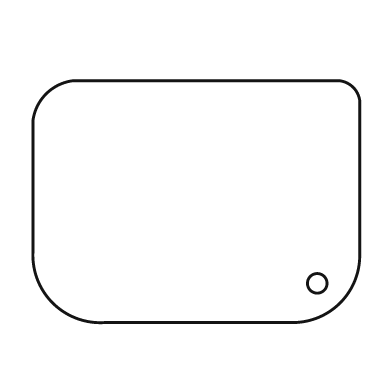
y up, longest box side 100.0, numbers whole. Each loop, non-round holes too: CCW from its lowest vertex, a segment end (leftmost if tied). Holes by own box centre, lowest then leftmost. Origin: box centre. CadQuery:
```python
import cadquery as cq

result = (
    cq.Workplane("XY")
    .moveTo(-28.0, -37.0)
    .lineTo(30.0, -37.0)
    .threePointArc((44.0, -31.0), (50.0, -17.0))
    .lineTo(50.0, 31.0)
    .threePointArc((48.0, 35.0), (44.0, 37.0))
    .lineTo(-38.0, 37.0)
    .threePointArc((-46.0, 33.0), (-50.0, 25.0))
    .lineTo(-50.0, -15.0)
    .threePointArc((-44.0, -31.0), (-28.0, -37.0))
    .close()
    .moveTo(37.0, -25.0)
    .circle(3.0)
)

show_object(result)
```